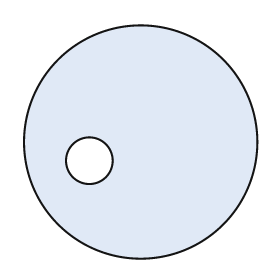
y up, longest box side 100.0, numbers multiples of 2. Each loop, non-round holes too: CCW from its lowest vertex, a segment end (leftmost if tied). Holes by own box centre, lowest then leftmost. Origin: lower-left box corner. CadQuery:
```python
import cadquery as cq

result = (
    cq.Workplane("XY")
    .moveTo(50.0, 50.0)
    .circle(50.0)
    .moveTo(28.0, 42.0)
    .circle(10.0)
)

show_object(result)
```